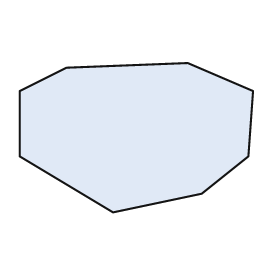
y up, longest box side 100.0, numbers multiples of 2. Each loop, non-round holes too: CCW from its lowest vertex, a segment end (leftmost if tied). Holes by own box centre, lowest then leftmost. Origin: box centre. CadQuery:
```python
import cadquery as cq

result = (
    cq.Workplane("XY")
    .moveTo(-10.0, -32.0)
    .lineTo(28.0, -24.0)
    .lineTo(48.0, -8.0)
    .lineTo(50.0, 20.0)
    .lineTo(22.0, 32.0)
    .lineTo(-30.0, 30.0)
    .lineTo(-50.0, 20.0)
    .lineTo(-50.0, -8.0)
    .close()
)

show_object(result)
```